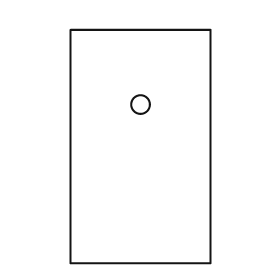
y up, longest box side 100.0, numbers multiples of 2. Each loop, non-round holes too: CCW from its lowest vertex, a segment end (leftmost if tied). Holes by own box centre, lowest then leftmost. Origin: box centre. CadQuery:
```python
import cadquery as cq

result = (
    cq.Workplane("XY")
    .moveTo(-30.0, -50.0)
    .lineTo(30.0, -50.0)
    .lineTo(30.0, 50.0)
    .lineTo(-30.0, 50.0)
    .close()
    .moveTo(0.0, 18.0)
    .circle(4.0)
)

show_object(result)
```